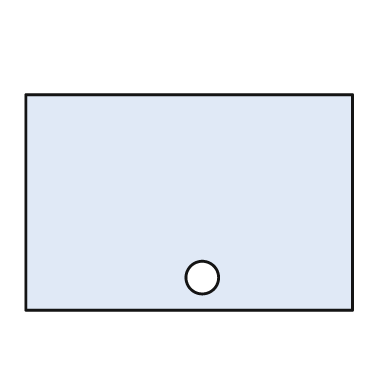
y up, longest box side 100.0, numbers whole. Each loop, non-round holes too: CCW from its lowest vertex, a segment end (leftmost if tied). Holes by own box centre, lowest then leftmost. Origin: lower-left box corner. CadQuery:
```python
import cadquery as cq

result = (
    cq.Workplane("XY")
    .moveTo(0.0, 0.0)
    .lineTo(100.0, 0.0)
    .lineTo(100.0, 66.0)
    .lineTo(0.0, 66.0)
    .close()
    .moveTo(54.0, 10.0)
    .circle(5.0)
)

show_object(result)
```